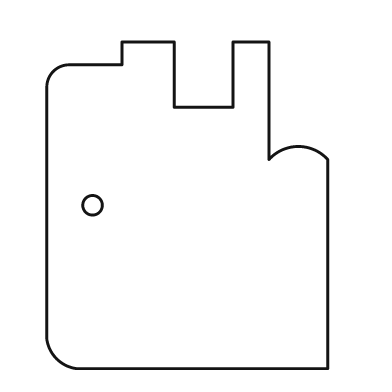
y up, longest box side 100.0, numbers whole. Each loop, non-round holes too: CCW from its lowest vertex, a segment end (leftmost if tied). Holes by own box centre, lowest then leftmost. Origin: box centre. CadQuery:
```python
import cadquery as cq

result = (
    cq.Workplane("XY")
    .moveTo(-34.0, -50.0)
    .lineTo(43.0, -50.0)
    .lineTo(43.0, 14.0)
    .threePointArc((34.0, 18.0), (25.0, 14.0))
    .lineTo(25.0, 50.0)
    .lineTo(14.0, 50.0)
    .lineTo(14.0, 30.0)
    .lineTo(-4.0, 30.0)
    .lineTo(-4.0, 50.0)
    .lineTo(-20.0, 50.0)
    .lineTo(-20.0, 43.0)
    .lineTo(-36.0, 43.0)
    .threePointArc((-41.0, 41.0), (-43.0, 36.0))
    .lineTo(-43.0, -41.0)
    .threePointArc((-40.0, -47.0), (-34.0, -50.0))
    .close()
    .moveTo(-29.0, 0.0)
    .circle(3.0)
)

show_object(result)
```